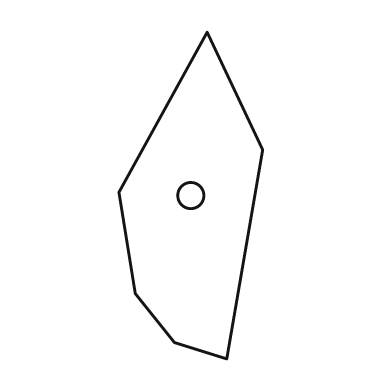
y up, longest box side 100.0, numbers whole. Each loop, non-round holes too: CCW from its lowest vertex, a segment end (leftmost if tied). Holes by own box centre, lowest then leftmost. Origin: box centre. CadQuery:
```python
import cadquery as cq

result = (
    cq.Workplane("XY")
    .moveTo(11.0, -50.0)
    .lineTo(22.0, 14.0)
    .lineTo(5.0, 50.0)
    .lineTo(-22.0, 1.0)
    .lineTo(-17.0, -30.0)
    .lineTo(-5.0, -45.0)
    .close()
    .moveTo(0.0, 0.0)
    .circle(4.0)
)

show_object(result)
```